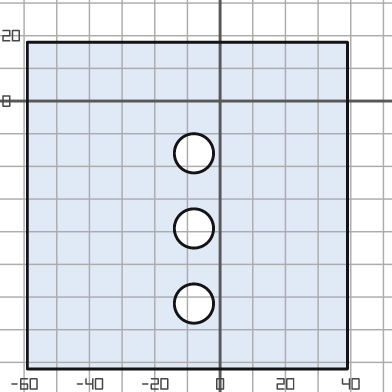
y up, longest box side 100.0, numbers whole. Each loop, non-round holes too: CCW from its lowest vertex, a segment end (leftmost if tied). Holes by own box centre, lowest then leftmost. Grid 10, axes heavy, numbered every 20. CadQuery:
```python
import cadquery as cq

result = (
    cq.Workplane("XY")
    .moveTo(-59.0, -82.0)
    .lineTo(39.0, -82.0)
    .lineTo(39.0, 18.0)
    .lineTo(-59.0, 18.0)
    .close()
    .moveTo(-8.0, -62.0)
    .circle(6.0)
    .moveTo(-8.0, -39.0)
    .circle(6.0)
    .moveTo(-8.0, -16.0)
    .circle(6.0)
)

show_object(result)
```